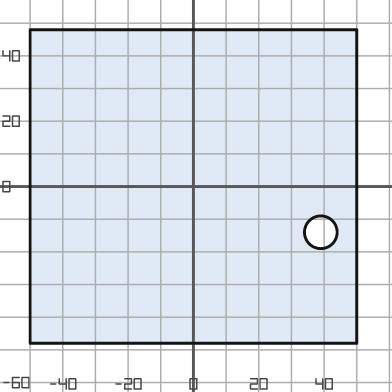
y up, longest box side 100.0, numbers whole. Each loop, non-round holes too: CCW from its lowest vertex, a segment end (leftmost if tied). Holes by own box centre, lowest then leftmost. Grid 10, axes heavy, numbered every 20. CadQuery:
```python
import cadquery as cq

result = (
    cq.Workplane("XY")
    .moveTo(-50.0, -48.0)
    .lineTo(50.0, -48.0)
    .lineTo(50.0, 48.0)
    .lineTo(-50.0, 48.0)
    .close()
    .moveTo(39.0, -14.0)
    .circle(5.0)
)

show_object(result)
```